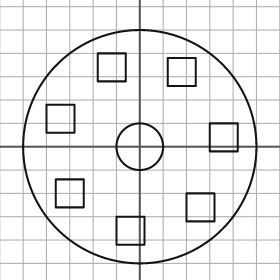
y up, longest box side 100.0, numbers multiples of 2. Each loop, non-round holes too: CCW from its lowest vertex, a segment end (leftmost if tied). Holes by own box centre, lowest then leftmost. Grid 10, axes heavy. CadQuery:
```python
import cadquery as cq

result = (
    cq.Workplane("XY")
    .moveTo(0.0, 0.0)
    .circle(50.0)
    .moveTo(-10.0, -42.0)
    .lineTo(2.0, -42.0)
    .lineTo(2.0, -30.0)
    .lineTo(-10.0, -30.0)
    .close()
    .moveTo(20.0, -32.0)
    .lineTo(32.0, -32.0)
    .lineTo(32.0, -20.0)
    .lineTo(20.0, -20.0)
    .close()
    .moveTo(-36.0, -26.0)
    .lineTo(-24.0, -26.0)
    .lineTo(-24.0, -14.0)
    .lineTo(-36.0, -14.0)
    .close()
    .moveTo(0.0, 0.0)
    .circle(10.0)
    .moveTo(30.0, -2.0)
    .lineTo(42.0, -2.0)
    .lineTo(42.0, 10.0)
    .lineTo(30.0, 10.0)
    .close()
    .moveTo(-40.0, 6.0)
    .lineTo(-28.0, 6.0)
    .lineTo(-28.0, 18.0)
    .lineTo(-40.0, 18.0)
    .close()
    .moveTo(12.0, 26.0)
    .lineTo(24.0, 26.0)
    .lineTo(24.0, 38.0)
    .lineTo(12.0, 38.0)
    .close()
    .moveTo(-18.0, 28.0)
    .lineTo(-6.0, 28.0)
    .lineTo(-6.0, 40.0)
    .lineTo(-18.0, 40.0)
    .close()
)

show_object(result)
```